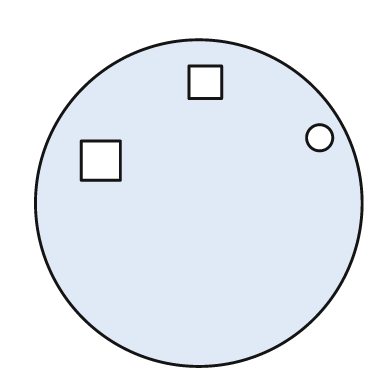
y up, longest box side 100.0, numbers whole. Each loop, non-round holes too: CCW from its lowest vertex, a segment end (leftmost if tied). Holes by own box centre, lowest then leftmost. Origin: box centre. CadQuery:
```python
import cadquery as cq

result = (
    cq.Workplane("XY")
    .moveTo(0.0, 0.0)
    .circle(50.0)
    .moveTo(-36.0, 7.0)
    .lineTo(-24.0, 7.0)
    .lineTo(-24.0, 19.0)
    .lineTo(-36.0, 19.0)
    .close()
    .moveTo(37.0, 20.0)
    .circle(4.0)
    .moveTo(-3.0, 32.0)
    .lineTo(7.0, 32.0)
    .lineTo(7.0, 42.0)
    .lineTo(-3.0, 42.0)
    .close()
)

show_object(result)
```